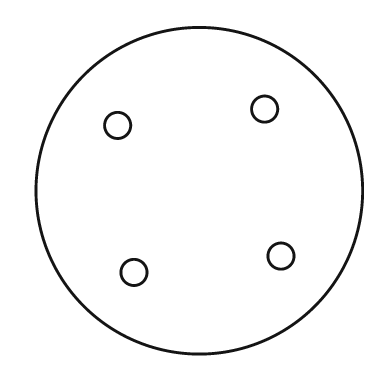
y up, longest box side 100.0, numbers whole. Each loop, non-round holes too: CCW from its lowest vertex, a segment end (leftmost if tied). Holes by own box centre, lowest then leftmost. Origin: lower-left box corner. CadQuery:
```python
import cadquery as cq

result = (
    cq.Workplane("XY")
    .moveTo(50.0, 50.0)
    .circle(50.0)
    .moveTo(30.0, 25.0)
    .circle(4.0)
    .moveTo(75.0, 30.0)
    .circle(4.0)
    .moveTo(25.0, 70.0)
    .circle(4.0)
    .moveTo(70.0, 75.0)
    .circle(4.0)
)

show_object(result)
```